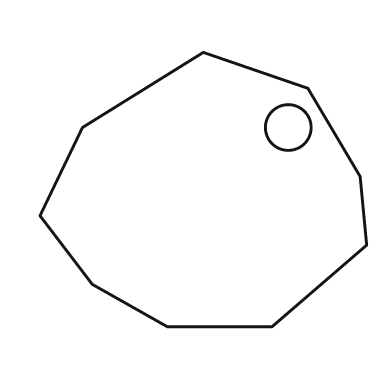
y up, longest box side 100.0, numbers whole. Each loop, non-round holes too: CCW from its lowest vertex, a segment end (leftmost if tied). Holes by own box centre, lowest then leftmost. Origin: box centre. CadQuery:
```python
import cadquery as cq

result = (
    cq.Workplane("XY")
    .moveTo(-11.0, -42.0)
    .lineTo(21.0, -42.0)
    .lineTo(50.0, -17.0)
    .lineTo(48.0, 4.0)
    .lineTo(32.0, 31.0)
    .lineTo(0.0, 42.0)
    .lineTo(-37.0, 19.0)
    .lineTo(-50.0, -8.0)
    .lineTo(-34.0, -29.0)
    .close()
    .moveTo(26.0, 19.0)
    .circle(7.0)
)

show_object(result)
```